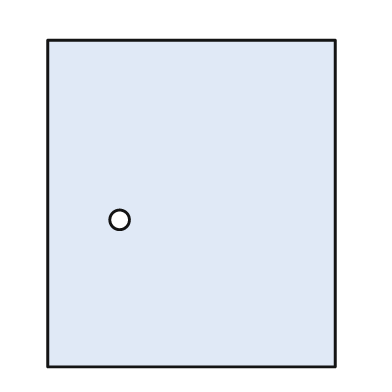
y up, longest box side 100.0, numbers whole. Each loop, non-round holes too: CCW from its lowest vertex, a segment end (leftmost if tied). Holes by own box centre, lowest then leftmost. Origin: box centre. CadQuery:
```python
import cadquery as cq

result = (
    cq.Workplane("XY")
    .moveTo(-44.0, -50.0)
    .lineTo(44.0, -50.0)
    .lineTo(44.0, 50.0)
    .lineTo(-44.0, 50.0)
    .close()
    .moveTo(-22.0, -5.0)
    .circle(3.0)
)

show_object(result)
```